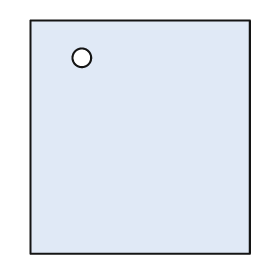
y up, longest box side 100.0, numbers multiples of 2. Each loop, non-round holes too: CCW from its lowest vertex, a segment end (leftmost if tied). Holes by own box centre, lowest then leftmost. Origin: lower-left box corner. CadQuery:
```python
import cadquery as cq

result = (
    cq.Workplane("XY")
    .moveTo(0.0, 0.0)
    .lineTo(94.0, 0.0)
    .lineTo(94.0, 100.0)
    .lineTo(0.0, 100.0)
    .close()
    .moveTo(22.0, 84.0)
    .circle(4.0)
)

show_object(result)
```